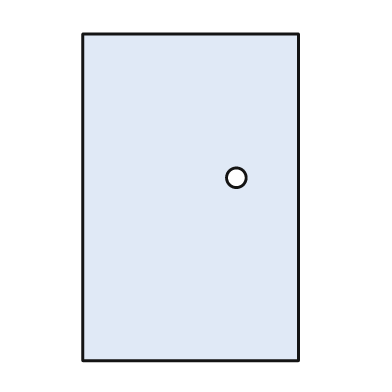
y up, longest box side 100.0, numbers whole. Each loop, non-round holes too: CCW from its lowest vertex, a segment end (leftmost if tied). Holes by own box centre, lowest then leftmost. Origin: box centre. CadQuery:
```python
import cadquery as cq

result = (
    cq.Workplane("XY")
    .moveTo(-33.0, -50.0)
    .lineTo(33.0, -50.0)
    .lineTo(33.0, 50.0)
    .lineTo(-33.0, 50.0)
    .close()
    .moveTo(14.0, 6.0)
    .circle(3.0)
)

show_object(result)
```